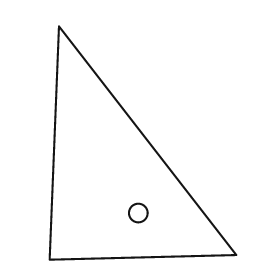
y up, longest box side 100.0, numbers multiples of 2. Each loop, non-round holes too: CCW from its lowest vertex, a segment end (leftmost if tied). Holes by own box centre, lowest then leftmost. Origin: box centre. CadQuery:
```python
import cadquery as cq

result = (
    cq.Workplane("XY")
    .moveTo(-40.0, -50.0)
    .lineTo(40.0, -48.0)
    .lineTo(-36.0, 50.0)
    .close()
    .moveTo(-2.0, -30.0)
    .circle(4.0)
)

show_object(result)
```